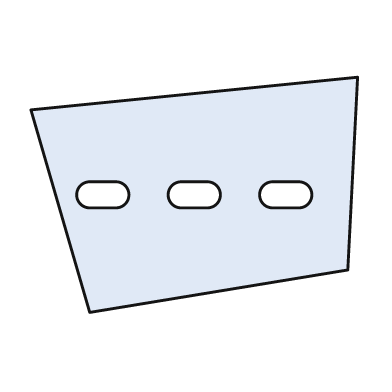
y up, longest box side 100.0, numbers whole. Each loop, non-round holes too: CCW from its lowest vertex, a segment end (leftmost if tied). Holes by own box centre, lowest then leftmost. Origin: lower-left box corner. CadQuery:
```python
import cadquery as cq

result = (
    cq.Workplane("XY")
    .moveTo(18.0, 0.0)
    .lineTo(97.0, 13.0)
    .lineTo(100.0, 72.0)
    .lineTo(0.0, 62.0)
    .close()
    .moveTo(18.0, 32.0)
    .lineTo(26.0, 32.0)
    .threePointArc((30.0, 36.0), (26.0, 40.0))
    .lineTo(18.0, 40.0)
    .threePointArc((14.0, 36.0), (18.0, 32.0))
    .close()
    .moveTo(46.0, 32.0)
    .lineTo(54.0, 32.0)
    .threePointArc((58.0, 36.0), (54.0, 40.0))
    .lineTo(46.0, 40.0)
    .threePointArc((42.0, 36.0), (46.0, 32.0))
    .close()
    .moveTo(74.0, 32.0)
    .lineTo(82.0, 32.0)
    .threePointArc((86.0, 36.0), (82.0, 40.0))
    .lineTo(74.0, 40.0)
    .threePointArc((70.0, 36.0), (74.0, 32.0))
    .close()
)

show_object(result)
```